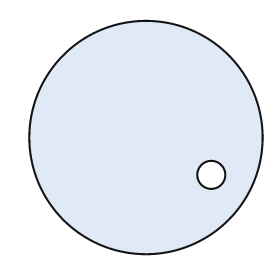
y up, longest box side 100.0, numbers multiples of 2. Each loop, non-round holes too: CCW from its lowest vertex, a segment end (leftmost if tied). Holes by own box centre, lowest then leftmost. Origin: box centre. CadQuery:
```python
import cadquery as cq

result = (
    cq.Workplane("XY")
    .moveTo(0.0, 0.0)
    .circle(50.0)
    .moveTo(28.0, -16.0)
    .circle(6.0)
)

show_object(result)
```